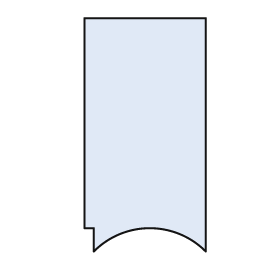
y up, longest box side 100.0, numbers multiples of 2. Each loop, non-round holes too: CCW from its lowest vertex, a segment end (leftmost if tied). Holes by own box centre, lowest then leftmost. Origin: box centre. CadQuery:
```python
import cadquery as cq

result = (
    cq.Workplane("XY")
    .moveTo(-22.0, -50.0)
    .threePointArc((2.0, -40.0), (26.0, -50.0))
    .lineTo(26.0, 50.0)
    .lineTo(-26.0, 50.0)
    .lineTo(-26.0, -40.0)
    .lineTo(-22.0, -40.0)
    .close()
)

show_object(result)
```